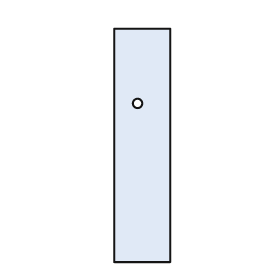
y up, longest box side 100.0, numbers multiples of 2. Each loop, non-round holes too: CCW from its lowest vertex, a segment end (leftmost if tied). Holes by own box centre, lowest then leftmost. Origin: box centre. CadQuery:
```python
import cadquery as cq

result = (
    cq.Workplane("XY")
    .moveTo(-12.0, -50.0)
    .lineTo(12.0, -50.0)
    .lineTo(12.0, 50.0)
    .lineTo(-12.0, 50.0)
    .close()
    .moveTo(-2.0, 18.0)
    .circle(2.0)
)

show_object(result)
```